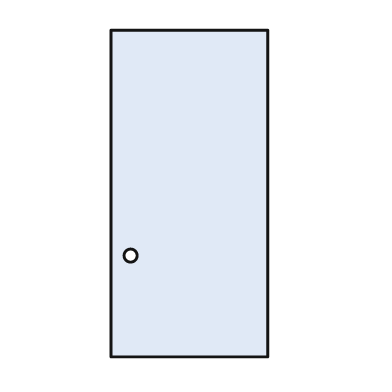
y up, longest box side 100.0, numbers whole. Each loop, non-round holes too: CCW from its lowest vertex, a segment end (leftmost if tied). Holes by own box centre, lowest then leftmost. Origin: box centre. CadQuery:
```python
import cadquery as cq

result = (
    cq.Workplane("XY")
    .moveTo(-24.0, -50.0)
    .lineTo(24.0, -50.0)
    .lineTo(24.0, 50.0)
    .lineTo(-24.0, 50.0)
    .close()
    .moveTo(-18.0, -19.0)
    .circle(2.0)
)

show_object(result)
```